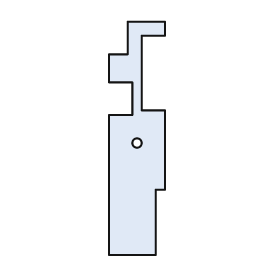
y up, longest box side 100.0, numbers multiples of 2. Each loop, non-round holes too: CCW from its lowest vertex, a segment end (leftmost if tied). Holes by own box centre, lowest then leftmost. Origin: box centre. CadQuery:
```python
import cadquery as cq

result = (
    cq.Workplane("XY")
    .moveTo(-12.0, -50.0)
    .lineTo(8.0, -50.0)
    .lineTo(8.0, -22.0)
    .lineTo(12.0, -22.0)
    .lineTo(12.0, 12.0)
    .lineTo(2.0, 12.0)
    .lineTo(2.0, 44.0)
    .lineTo(12.0, 44.0)
    .lineTo(12.0, 50.0)
    .lineTo(-4.0, 50.0)
    .lineTo(-4.0, 36.0)
    .lineTo(-12.0, 36.0)
    .lineTo(-12.0, 24.0)
    .lineTo(-2.0, 24.0)
    .lineTo(-2.0, 10.0)
    .lineTo(-12.0, 10.0)
    .close()
    .moveTo(0.0, -2.0)
    .circle(2.0)
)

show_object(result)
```